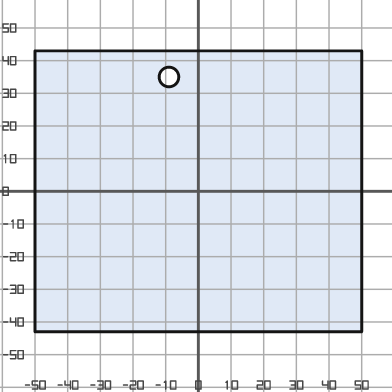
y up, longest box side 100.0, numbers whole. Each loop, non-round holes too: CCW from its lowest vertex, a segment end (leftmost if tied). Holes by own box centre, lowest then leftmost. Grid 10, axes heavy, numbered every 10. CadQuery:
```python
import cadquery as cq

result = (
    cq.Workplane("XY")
    .moveTo(-50.0, -43.0)
    .lineTo(50.0, -43.0)
    .lineTo(50.0, 43.0)
    .lineTo(-50.0, 43.0)
    .close()
    .moveTo(-9.0, 35.0)
    .circle(3.0)
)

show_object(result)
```